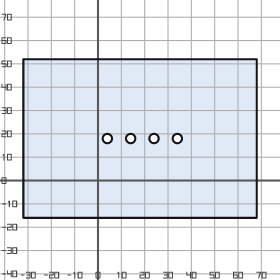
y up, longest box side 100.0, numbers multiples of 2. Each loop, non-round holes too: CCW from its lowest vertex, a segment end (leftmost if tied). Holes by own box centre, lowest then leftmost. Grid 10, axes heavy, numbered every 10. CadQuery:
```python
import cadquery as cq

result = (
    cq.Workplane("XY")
    .moveTo(-32.0, -16.0)
    .lineTo(68.0, -16.0)
    .lineTo(68.0, 52.0)
    .lineTo(-32.0, 52.0)
    .close()
    .moveTo(4.0, 18.0)
    .circle(2.0)
    .moveTo(14.0, 18.0)
    .circle(2.0)
    .moveTo(24.0, 18.0)
    .circle(2.0)
    .moveTo(34.0, 18.0)
    .circle(2.0)
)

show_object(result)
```